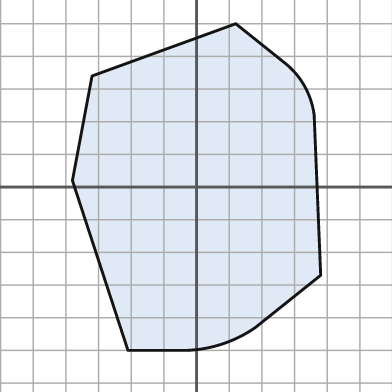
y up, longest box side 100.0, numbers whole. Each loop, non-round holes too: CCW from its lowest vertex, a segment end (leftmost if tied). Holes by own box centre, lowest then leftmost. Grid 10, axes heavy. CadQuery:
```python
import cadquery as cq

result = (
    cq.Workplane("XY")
    .moveTo(-21.0, -50.0)
    .lineTo(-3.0, -50.0)
    .threePointArc((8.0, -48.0), (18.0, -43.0))
    .lineTo(38.0, -27.0)
    .lineTo(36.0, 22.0)
    .threePointArc((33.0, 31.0), (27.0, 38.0))
    .lineTo(12.0, 50.0)
    .lineTo(-32.0, 34.0)
    .lineTo(-38.0, 2.0)
    .close()
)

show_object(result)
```